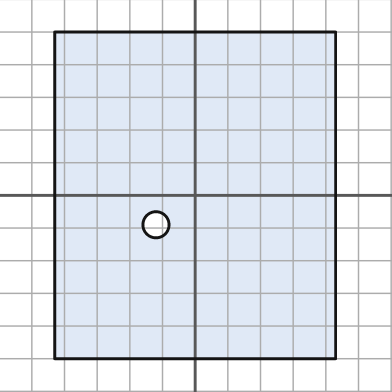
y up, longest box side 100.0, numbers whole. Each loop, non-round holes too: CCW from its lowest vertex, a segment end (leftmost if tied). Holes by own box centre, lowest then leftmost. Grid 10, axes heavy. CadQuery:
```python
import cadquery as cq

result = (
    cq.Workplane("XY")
    .moveTo(-43.0, -50.0)
    .lineTo(43.0, -50.0)
    .lineTo(43.0, 50.0)
    .lineTo(-43.0, 50.0)
    .close()
    .moveTo(-12.0, -9.0)
    .circle(4.0)
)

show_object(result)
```